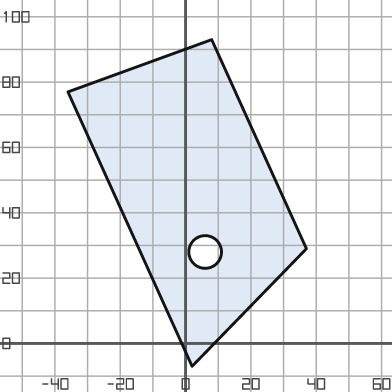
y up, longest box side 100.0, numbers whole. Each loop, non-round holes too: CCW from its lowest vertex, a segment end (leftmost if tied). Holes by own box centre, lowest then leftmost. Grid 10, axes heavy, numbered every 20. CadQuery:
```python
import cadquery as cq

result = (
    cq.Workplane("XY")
    .moveTo(2.0, -7.0)
    .lineTo(37.0, 29.0)
    .lineTo(8.0, 93.0)
    .lineTo(-36.0, 77.0)
    .close()
    .moveTo(6.0, 28.0)
    .circle(5.0)
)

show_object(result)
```